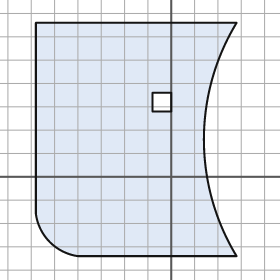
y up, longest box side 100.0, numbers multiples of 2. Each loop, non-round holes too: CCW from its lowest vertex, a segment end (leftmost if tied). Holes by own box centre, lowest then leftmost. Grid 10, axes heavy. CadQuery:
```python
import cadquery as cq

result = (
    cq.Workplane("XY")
    .moveTo(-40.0, -34.0)
    .lineTo(28.0, -34.0)
    .threePointArc((14.0, 16.0), (28.0, 66.0))
    .lineTo(-58.0, 66.0)
    .lineTo(-58.0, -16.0)
    .threePointArc((-52.0, -28.0), (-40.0, -34.0))
    .close()
    .moveTo(-8.0, 28.0)
    .lineTo(0.0, 28.0)
    .lineTo(0.0, 36.0)
    .lineTo(-8.0, 36.0)
    .close()
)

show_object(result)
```